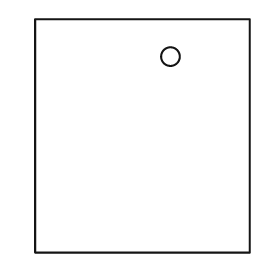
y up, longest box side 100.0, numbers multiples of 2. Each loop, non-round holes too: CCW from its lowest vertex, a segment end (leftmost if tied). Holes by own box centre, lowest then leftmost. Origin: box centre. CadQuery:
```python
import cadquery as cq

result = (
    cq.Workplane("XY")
    .moveTo(-46.0, -50.0)
    .lineTo(46.0, -50.0)
    .lineTo(46.0, 50.0)
    .lineTo(-46.0, 50.0)
    .close()
    .moveTo(12.0, 34.0)
    .circle(4.0)
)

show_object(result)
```